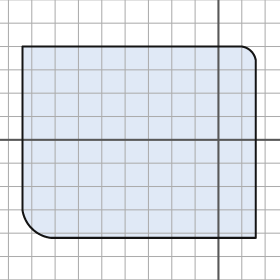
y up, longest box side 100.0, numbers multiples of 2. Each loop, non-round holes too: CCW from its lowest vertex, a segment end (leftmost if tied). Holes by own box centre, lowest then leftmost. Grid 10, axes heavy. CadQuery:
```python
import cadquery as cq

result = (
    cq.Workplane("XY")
    .moveTo(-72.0, -42.0)
    .lineTo(16.0, -42.0)
    .lineTo(16.0, 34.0)
    .threePointArc((14.0, 38.0), (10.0, 40.0))
    .lineTo(-84.0, 40.0)
    .lineTo(-84.0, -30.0)
    .threePointArc((-80.0, -38.0), (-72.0, -42.0))
    .close()
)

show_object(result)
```